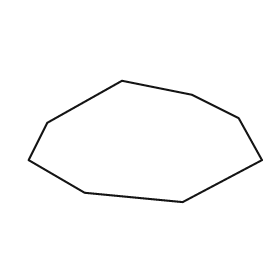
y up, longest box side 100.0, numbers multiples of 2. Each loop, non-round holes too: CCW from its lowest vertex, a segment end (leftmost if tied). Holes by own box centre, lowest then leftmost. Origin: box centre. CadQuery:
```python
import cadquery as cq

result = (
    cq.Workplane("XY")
    .moveTo(16.0, -26.0)
    .lineTo(50.0, -8.0)
    .lineTo(40.0, 10.0)
    .lineTo(20.0, 20.0)
    .lineTo(-10.0, 26.0)
    .lineTo(-42.0, 8.0)
    .lineTo(-50.0, -8.0)
    .lineTo(-26.0, -22.0)
    .close()
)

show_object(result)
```